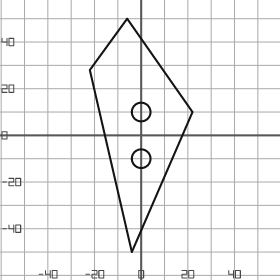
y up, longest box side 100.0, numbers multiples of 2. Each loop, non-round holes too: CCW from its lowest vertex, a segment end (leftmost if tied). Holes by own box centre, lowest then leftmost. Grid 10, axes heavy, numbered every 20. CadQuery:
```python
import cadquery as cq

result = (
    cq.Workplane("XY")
    .moveTo(-4.0, -50.0)
    .lineTo(22.0, 10.0)
    .lineTo(-6.0, 50.0)
    .lineTo(-22.0, 28.0)
    .close()
    .moveTo(0.0, -10.0)
    .circle(4.0)
    .moveTo(0.0, 10.0)
    .circle(4.0)
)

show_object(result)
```